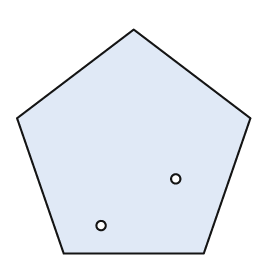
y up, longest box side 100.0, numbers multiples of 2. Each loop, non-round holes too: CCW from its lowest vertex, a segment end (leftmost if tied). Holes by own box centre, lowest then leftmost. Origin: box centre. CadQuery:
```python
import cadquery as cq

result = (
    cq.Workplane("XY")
    .moveTo(-30.0, -48.0)
    .lineTo(30.0, -48.0)
    .lineTo(50.0, 10.0)
    .lineTo(0.0, 48.0)
    .lineTo(-50.0, 10.0)
    .close()
    .moveTo(-14.0, -36.0)
    .circle(2.0)
    .moveTo(18.0, -16.0)
    .circle(2.0)
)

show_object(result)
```